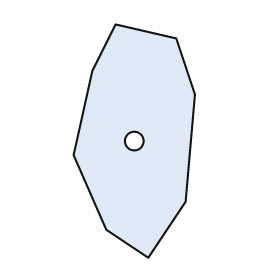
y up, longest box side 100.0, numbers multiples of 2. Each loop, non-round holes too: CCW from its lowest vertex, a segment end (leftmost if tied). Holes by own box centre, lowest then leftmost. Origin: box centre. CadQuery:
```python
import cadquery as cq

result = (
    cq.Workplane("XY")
    .moveTo(6.0, -50.0)
    .lineTo(22.0, -26.0)
    .lineTo(26.0, 20.0)
    .lineTo(18.0, 44.0)
    .lineTo(-8.0, 50.0)
    .lineTo(-18.0, 30.0)
    .lineTo(-26.0, -6.0)
    .lineTo(-12.0, -38.0)
    .close()
    .moveTo(0.0, 0.0)
    .circle(4.0)
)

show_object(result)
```